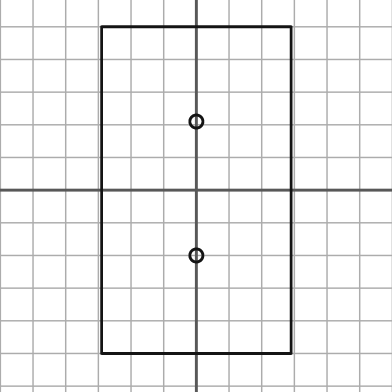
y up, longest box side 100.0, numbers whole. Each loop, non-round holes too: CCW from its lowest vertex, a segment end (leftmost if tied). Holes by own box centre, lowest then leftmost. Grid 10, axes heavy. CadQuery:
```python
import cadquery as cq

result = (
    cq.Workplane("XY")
    .moveTo(-29.0, -50.0)
    .lineTo(29.0, -50.0)
    .lineTo(29.0, 50.0)
    .lineTo(-29.0, 50.0)
    .close()
    .moveTo(0.0, -20.0)
    .circle(2.0)
    .moveTo(0.0, 21.0)
    .circle(2.0)
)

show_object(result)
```